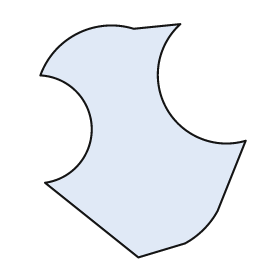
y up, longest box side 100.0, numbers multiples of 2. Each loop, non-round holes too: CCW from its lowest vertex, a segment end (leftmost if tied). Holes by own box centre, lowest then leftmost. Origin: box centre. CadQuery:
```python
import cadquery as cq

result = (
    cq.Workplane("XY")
    .moveTo(-2.0, -50.0)
    .lineTo(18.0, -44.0)
    .threePointArc((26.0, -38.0), (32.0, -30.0))
    .lineTo(44.0, 0.0)
    .threePointArc((10.0, 14.0), (16.0, 50.0))
    .lineTo(-4.0, 48.0)
    .threePointArc((-28.0, 46.0), (-44.0, 28.0))
    .threePointArc((-22.0, 6.0), (-42.0, -18.0))
    .close()
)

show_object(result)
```